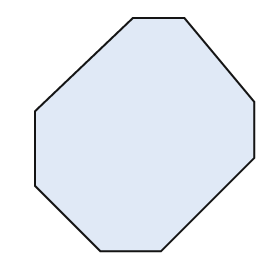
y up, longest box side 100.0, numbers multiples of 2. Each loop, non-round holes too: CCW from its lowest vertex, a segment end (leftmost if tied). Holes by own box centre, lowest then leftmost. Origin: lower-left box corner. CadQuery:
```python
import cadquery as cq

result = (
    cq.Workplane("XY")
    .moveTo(28.0, 0.0)
    .lineTo(54.0, 0.0)
    .lineTo(94.0, 40.0)
    .lineTo(94.0, 64.0)
    .lineTo(64.0, 100.0)
    .lineTo(42.0, 100.0)
    .lineTo(0.0, 60.0)
    .lineTo(0.0, 28.0)
    .close()
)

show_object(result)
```